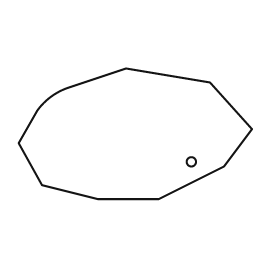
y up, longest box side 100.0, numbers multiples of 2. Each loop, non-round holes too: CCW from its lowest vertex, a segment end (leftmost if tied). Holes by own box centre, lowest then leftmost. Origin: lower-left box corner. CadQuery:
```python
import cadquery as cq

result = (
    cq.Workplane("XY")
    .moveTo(34.0, 0.0)
    .lineTo(60.0, 0.0)
    .lineTo(88.0, 14.0)
    .lineTo(100.0, 30.0)
    .lineTo(82.0, 50.0)
    .lineTo(46.0, 56.0)
    .lineTo(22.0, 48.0)
    .threePointArc((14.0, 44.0), (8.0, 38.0))
    .lineTo(0.0, 24.0)
    .lineTo(10.0, 6.0)
    .close()
    .moveTo(74.0, 16.0)
    .circle(2.0)
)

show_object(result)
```